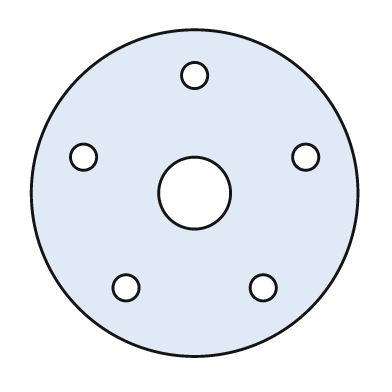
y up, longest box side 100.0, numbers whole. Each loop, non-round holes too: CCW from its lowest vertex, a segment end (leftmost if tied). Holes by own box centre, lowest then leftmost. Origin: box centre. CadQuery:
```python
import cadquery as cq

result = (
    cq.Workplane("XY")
    .moveTo(0.0, 0.0)
    .circle(50.0)
    .moveTo(-21.0, -29.0)
    .circle(4.0)
    .moveTo(21.0, -29.0)
    .circle(4.0)
    .moveTo(0.0, 0.0)
    .circle(11.0)
    .moveTo(-34.0, 11.0)
    .circle(4.0)
    .moveTo(34.0, 11.0)
    .circle(4.0)
    .moveTo(0.0, 36.0)
    .circle(4.0)
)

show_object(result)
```